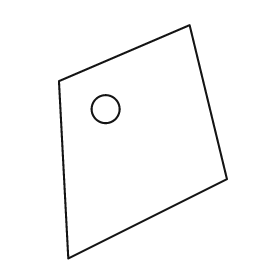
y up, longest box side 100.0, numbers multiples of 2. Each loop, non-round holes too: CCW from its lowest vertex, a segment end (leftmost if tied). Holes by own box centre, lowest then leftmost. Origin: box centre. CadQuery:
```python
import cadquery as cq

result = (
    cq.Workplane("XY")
    .moveTo(-32.0, -50.0)
    .lineTo(36.0, -16.0)
    .lineTo(20.0, 50.0)
    .lineTo(-36.0, 26.0)
    .close()
    .moveTo(-16.0, 14.0)
    .circle(6.0)
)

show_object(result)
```